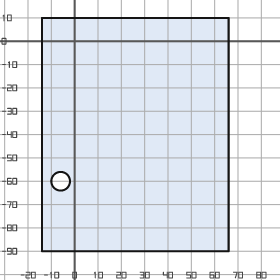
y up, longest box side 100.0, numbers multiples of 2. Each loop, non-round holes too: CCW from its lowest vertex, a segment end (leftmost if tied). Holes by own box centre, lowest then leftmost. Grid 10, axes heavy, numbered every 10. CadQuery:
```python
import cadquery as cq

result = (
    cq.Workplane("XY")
    .moveTo(-14.0, -90.0)
    .lineTo(66.0, -90.0)
    .lineTo(66.0, 10.0)
    .lineTo(-14.0, 10.0)
    .close()
    .moveTo(-6.0, -60.0)
    .circle(4.0)
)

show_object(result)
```